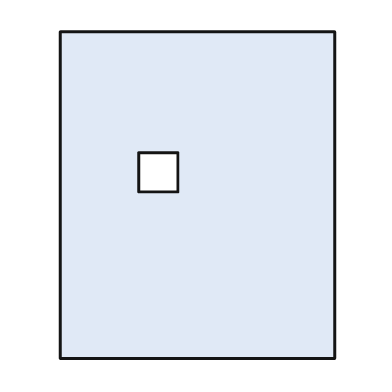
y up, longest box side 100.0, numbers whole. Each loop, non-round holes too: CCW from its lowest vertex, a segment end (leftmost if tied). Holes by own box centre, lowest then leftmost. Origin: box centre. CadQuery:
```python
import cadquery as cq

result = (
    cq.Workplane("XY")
    .moveTo(-42.0, -50.0)
    .lineTo(42.0, -50.0)
    .lineTo(42.0, 50.0)
    .lineTo(-42.0, 50.0)
    .close()
    .moveTo(-18.0, 1.0)
    .lineTo(-6.0, 1.0)
    .lineTo(-6.0, 13.0)
    .lineTo(-18.0, 13.0)
    .close()
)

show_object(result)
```